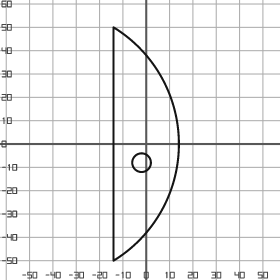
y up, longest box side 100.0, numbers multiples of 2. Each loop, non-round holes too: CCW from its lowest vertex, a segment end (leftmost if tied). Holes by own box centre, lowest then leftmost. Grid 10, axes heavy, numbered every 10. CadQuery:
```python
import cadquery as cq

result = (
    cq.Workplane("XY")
    .moveTo(-14.0, -50.0)
    .threePointArc((14.0, 0.0), (-14.0, 50.0))
    .close()
    .moveTo(-2.0, -8.0)
    .circle(4.0)
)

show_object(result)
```